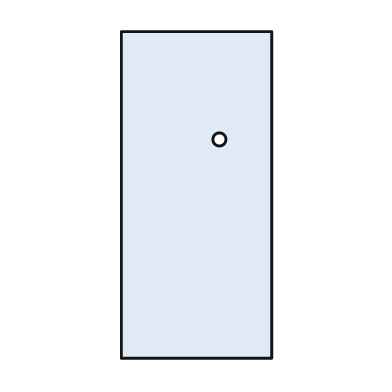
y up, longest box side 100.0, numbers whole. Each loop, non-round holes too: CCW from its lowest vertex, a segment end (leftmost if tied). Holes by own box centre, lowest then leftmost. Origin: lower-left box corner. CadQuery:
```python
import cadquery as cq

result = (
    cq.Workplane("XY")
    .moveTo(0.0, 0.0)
    .lineTo(46.0, 0.0)
    .lineTo(46.0, 100.0)
    .lineTo(0.0, 100.0)
    .close()
    .moveTo(30.0, 67.0)
    .circle(2.0)
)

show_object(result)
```